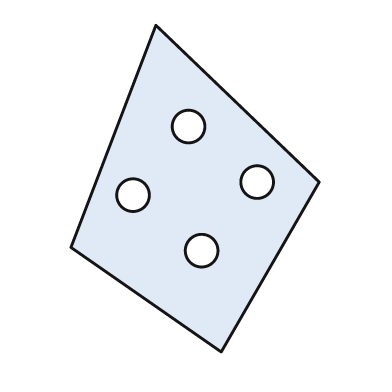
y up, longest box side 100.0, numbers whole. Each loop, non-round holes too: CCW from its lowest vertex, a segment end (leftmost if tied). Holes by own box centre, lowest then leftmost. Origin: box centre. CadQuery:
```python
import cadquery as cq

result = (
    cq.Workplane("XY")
    .moveTo(8.0, -50.0)
    .lineTo(38.0, 2.0)
    .lineTo(-12.0, 50.0)
    .lineTo(-38.0, -18.0)
    .close()
    .moveTo(2.0, -19.0)
    .circle(5.0)
    .moveTo(-19.0, -2.0)
    .circle(5.0)
    .moveTo(19.0, 2.0)
    .circle(5.0)
    .moveTo(-2.0, 19.0)
    .circle(5.0)
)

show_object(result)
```